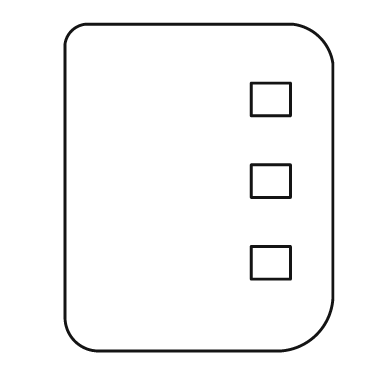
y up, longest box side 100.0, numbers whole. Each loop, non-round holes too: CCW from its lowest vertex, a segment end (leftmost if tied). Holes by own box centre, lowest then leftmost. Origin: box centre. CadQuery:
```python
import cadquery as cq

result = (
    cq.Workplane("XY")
    .moveTo(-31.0, -50.0)
    .lineTo(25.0, -50.0)
    .threePointArc((36.0, -45.0), (41.0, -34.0))
    .lineTo(41.0, 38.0)
    .threePointArc((37.0, 46.0), (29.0, 50.0))
    .lineTo(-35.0, 50.0)
    .threePointArc((-39.0, 48.0), (-41.0, 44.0))
    .lineTo(-41.0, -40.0)
    .threePointArc((-38.0, -47.0), (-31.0, -50.0))
    .close()
    .moveTo(16.0, -28.0)
    .lineTo(28.0, -28.0)
    .lineTo(28.0, -18.0)
    .lineTo(16.0, -18.0)
    .close()
    .moveTo(16.0, -3.0)
    .lineTo(28.0, -3.0)
    .lineTo(28.0, 7.0)
    .lineTo(16.0, 7.0)
    .close()
    .moveTo(16.0, 22.0)
    .lineTo(28.0, 22.0)
    .lineTo(28.0, 32.0)
    .lineTo(16.0, 32.0)
    .close()
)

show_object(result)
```